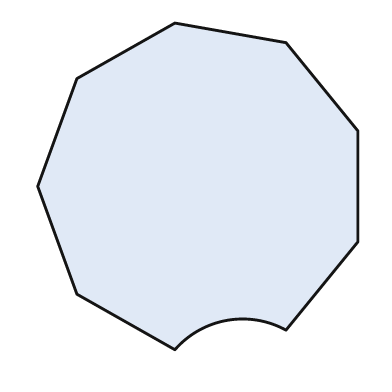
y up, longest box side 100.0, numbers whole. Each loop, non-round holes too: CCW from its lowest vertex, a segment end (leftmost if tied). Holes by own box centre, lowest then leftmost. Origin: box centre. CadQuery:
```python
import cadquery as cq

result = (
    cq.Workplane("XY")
    .moveTo(-7.0, -50.0)
    .threePointArc((9.0, -41.0), (27.0, -44.0))
    .lineTo(49.0, -17.0)
    .lineTo(49.0, 17.0)
    .lineTo(27.0, 44.0)
    .lineTo(-7.0, 50.0)
    .lineTo(-37.0, 33.0)
    .lineTo(-49.0, 0.0)
    .lineTo(-37.0, -33.0)
    .close()
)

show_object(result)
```